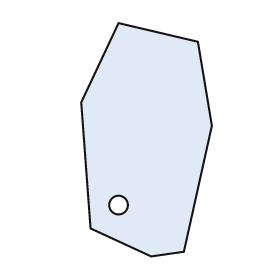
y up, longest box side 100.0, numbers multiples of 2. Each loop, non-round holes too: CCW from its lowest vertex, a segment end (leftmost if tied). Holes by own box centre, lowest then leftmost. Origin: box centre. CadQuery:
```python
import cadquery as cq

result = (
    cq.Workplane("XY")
    .moveTo(2.0, -50.0)
    .lineTo(16.0, -48.0)
    .lineTo(28.0, 6.0)
    .lineTo(22.0, 42.0)
    .lineTo(-12.0, 50.0)
    .lineTo(-28.0, 16.0)
    .lineTo(-24.0, -38.0)
    .close()
    .moveTo(-12.0, -28.0)
    .circle(4.0)
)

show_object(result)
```